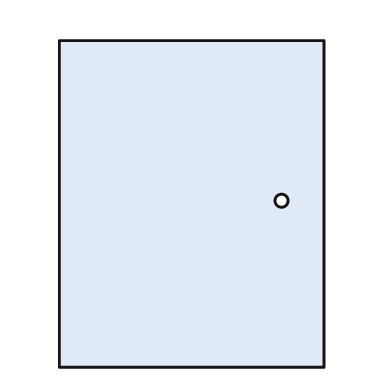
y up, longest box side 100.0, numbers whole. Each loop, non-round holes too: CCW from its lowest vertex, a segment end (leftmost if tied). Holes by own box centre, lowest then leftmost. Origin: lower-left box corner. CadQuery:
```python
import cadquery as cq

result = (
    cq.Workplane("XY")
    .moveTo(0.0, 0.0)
    .lineTo(81.0, 0.0)
    .lineTo(81.0, 100.0)
    .lineTo(0.0, 100.0)
    .close()
    .moveTo(68.0, 51.0)
    .circle(2.0)
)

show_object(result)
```